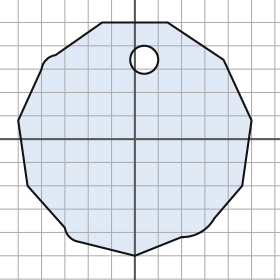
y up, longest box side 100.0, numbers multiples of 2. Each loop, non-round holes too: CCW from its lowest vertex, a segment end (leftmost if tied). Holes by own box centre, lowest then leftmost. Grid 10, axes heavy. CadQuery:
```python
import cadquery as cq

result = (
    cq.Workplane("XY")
    .moveTo(0.0, -50.0)
    .lineTo(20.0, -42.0)
    .threePointArc((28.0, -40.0), (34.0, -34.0))
    .lineTo(46.0, -20.0)
    .lineTo(50.0, 8.0)
    .lineTo(38.0, 34.0)
    .lineTo(14.0, 50.0)
    .lineTo(-14.0, 50.0)
    .lineTo(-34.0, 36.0)
    .threePointArc((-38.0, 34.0), (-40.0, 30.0))
    .lineTo(-50.0, 8.0)
    .lineTo(-46.0, -20.0)
    .lineTo(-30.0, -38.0)
    .threePointArc((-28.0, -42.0), (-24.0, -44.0))
    .close()
    .moveTo(4.0, 34.0)
    .circle(6.0)
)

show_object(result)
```